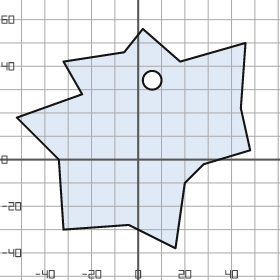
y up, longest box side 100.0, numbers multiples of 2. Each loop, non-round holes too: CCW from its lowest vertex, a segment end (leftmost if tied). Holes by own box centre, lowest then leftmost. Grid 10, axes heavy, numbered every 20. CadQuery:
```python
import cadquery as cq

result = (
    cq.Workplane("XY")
    .moveTo(16.0, -38.0)
    .lineTo(20.0, -10.0)
    .lineTo(28.0, -2.0)
    .lineTo(48.0, 4.0)
    .lineTo(44.0, 22.0)
    .lineTo(46.0, 50.0)
    .lineTo(18.0, 42.0)
    .lineTo(2.0, 56.0)
    .lineTo(-6.0, 46.0)
    .lineTo(-32.0, 42.0)
    .lineTo(-24.0, 28.0)
    .lineTo(-52.0, 18.0)
    .lineTo(-34.0, 0.0)
    .lineTo(-32.0, -30.0)
    .lineTo(-4.0, -28.0)
    .close()
    .moveTo(6.0, 34.0)
    .circle(4.0)
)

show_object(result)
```